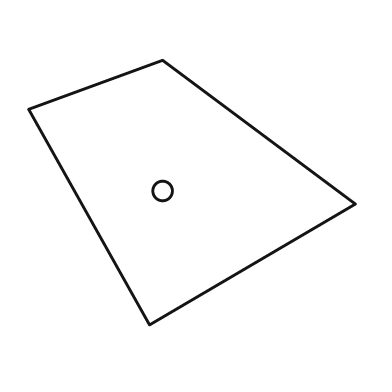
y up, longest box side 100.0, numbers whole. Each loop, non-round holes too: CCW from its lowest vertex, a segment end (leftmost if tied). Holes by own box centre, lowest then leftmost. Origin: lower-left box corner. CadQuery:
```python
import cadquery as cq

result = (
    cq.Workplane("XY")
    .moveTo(37.0, 0.0)
    .lineTo(100.0, 37.0)
    .lineTo(41.0, 81.0)
    .lineTo(0.0, 66.0)
    .close()
    .moveTo(41.0, 41.0)
    .circle(3.0)
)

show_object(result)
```